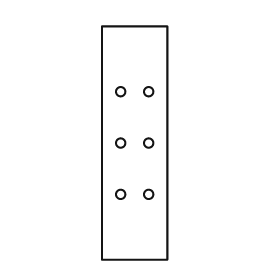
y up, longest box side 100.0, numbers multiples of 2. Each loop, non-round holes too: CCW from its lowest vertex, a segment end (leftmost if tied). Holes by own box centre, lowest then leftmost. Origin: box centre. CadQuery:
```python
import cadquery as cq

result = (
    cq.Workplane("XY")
    .moveTo(-14.0, -50.0)
    .lineTo(14.0, -50.0)
    .lineTo(14.0, 50.0)
    .lineTo(-14.0, 50.0)
    .close()
    .moveTo(-6.0, -22.0)
    .circle(2.0)
    .moveTo(6.0, -22.0)
    .circle(2.0)
    .moveTo(-6.0, 0.0)
    .circle(2.0)
    .moveTo(6.0, 0.0)
    .circle(2.0)
    .moveTo(-6.0, 22.0)
    .circle(2.0)
    .moveTo(6.0, 22.0)
    .circle(2.0)
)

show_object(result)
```